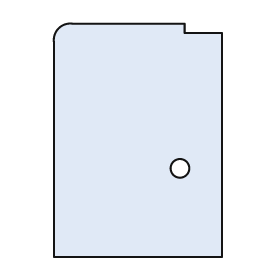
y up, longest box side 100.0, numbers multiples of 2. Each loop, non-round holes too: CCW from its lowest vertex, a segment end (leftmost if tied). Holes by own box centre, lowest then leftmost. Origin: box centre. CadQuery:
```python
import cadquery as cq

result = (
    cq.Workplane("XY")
    .moveTo(-36.0, -50.0)
    .lineTo(36.0, -50.0)
    .lineTo(36.0, 46.0)
    .lineTo(20.0, 46.0)
    .lineTo(20.0, 50.0)
    .lineTo(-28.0, 50.0)
    .threePointArc((-34.0, 48.0), (-36.0, 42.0))
    .close()
    .moveTo(18.0, -12.0)
    .circle(4.0)
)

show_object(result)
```